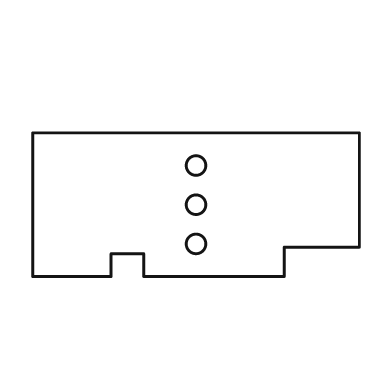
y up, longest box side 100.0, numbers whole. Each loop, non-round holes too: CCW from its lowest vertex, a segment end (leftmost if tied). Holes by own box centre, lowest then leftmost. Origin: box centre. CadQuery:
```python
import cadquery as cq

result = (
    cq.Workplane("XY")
    .moveTo(-50.0, -22.0)
    .lineTo(-26.0, -22.0)
    .lineTo(-26.0, -15.0)
    .lineTo(-16.0, -15.0)
    .lineTo(-16.0, -22.0)
    .lineTo(27.0, -22.0)
    .lineTo(27.0, -13.0)
    .lineTo(50.0, -13.0)
    .lineTo(50.0, 22.0)
    .lineTo(-50.0, 22.0)
    .close()
    .moveTo(0.0, -12.0)
    .circle(3.0)
    .moveTo(0.0, 0.0)
    .circle(3.0)
    .moveTo(0.0, 12.0)
    .circle(3.0)
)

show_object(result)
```